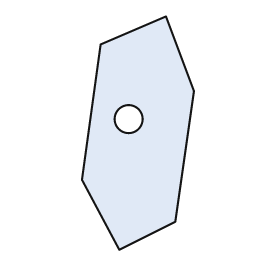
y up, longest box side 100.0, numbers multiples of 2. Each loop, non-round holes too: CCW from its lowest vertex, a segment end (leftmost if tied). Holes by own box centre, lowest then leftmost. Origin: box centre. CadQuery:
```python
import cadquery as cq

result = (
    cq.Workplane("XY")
    .moveTo(-8.0, -50.0)
    .lineTo(16.0, -38.0)
    .lineTo(24.0, 18.0)
    .lineTo(12.0, 50.0)
    .lineTo(-16.0, 38.0)
    .lineTo(-24.0, -20.0)
    .close()
    .moveTo(-4.0, 6.0)
    .circle(6.0)
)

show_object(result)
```